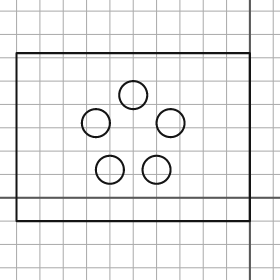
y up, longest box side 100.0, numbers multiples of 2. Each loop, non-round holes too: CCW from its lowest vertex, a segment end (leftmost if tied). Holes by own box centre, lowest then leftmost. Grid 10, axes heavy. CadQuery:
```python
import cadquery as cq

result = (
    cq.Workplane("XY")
    .moveTo(-100.0, -10.0)
    .lineTo(0.0, -10.0)
    .lineTo(0.0, 62.0)
    .lineTo(-100.0, 62.0)
    .close()
    .moveTo(-60.0, 12.0)
    .circle(6.0)
    .moveTo(-40.0, 12.0)
    .circle(6.0)
    .moveTo(-66.0, 32.0)
    .circle(6.0)
    .moveTo(-34.0, 32.0)
    .circle(6.0)
    .moveTo(-50.0, 44.0)
    .circle(6.0)
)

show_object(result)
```